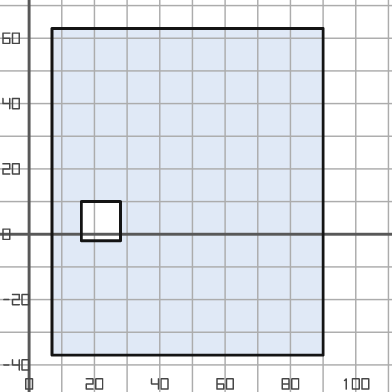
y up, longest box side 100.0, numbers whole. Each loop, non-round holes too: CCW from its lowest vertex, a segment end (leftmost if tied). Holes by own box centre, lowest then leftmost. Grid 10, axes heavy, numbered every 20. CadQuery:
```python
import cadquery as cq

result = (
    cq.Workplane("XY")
    .moveTo(7.0, -37.0)
    .lineTo(90.0, -37.0)
    .lineTo(90.0, 63.0)
    .lineTo(7.0, 63.0)
    .close()
    .moveTo(16.0, -2.0)
    .lineTo(28.0, -2.0)
    .lineTo(28.0, 10.0)
    .lineTo(16.0, 10.0)
    .close()
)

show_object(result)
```